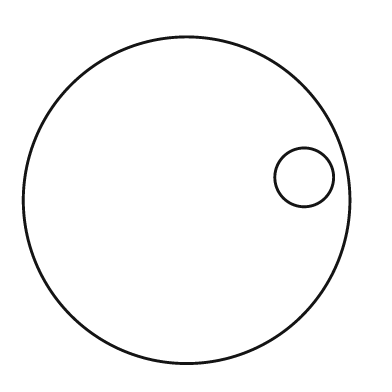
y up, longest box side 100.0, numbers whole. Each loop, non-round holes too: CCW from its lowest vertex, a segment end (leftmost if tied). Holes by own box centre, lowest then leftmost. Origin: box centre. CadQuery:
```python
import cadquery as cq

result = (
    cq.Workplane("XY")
    .moveTo(0.0, 0.0)
    .circle(50.0)
    .moveTo(36.0, 7.0)
    .circle(9.0)
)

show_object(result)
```